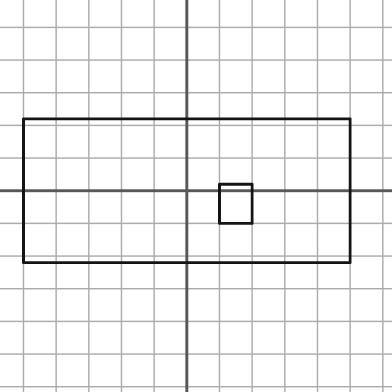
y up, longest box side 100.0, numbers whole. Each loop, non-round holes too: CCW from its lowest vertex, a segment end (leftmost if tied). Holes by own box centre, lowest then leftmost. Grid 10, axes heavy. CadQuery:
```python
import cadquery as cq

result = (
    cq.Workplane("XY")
    .moveTo(-50.0, -22.0)
    .lineTo(50.0, -22.0)
    .lineTo(50.0, 22.0)
    .lineTo(-50.0, 22.0)
    .close()
    .moveTo(10.0, -10.0)
    .lineTo(20.0, -10.0)
    .lineTo(20.0, 2.0)
    .lineTo(10.0, 2.0)
    .close()
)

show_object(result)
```